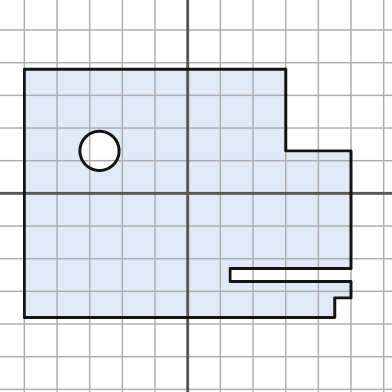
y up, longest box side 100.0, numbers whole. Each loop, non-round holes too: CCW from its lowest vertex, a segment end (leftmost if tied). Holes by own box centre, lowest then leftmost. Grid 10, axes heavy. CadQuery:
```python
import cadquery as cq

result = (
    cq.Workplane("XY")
    .moveTo(-50.0, -38.0)
    .lineTo(45.0, -38.0)
    .lineTo(45.0, -32.0)
    .lineTo(50.0, -32.0)
    .lineTo(50.0, -27.0)
    .lineTo(13.0, -27.0)
    .lineTo(13.0, -23.0)
    .lineTo(50.0, -23.0)
    .lineTo(50.0, 13.0)
    .lineTo(30.0, 13.0)
    .lineTo(30.0, 38.0)
    .lineTo(-50.0, 38.0)
    .close()
    .moveTo(-27.0, 13.0)
    .circle(6.0)
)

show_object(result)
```